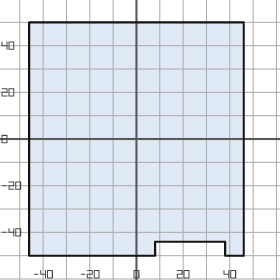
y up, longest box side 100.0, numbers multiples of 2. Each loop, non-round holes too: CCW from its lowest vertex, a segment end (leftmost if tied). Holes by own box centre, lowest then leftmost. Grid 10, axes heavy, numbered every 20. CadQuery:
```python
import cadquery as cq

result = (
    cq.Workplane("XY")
    .moveTo(-46.0, -50.0)
    .lineTo(8.0, -50.0)
    .lineTo(8.0, -44.0)
    .lineTo(38.0, -44.0)
    .lineTo(38.0, -50.0)
    .lineTo(46.0, -50.0)
    .lineTo(46.0, 50.0)
    .lineTo(-46.0, 50.0)
    .close()
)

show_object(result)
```